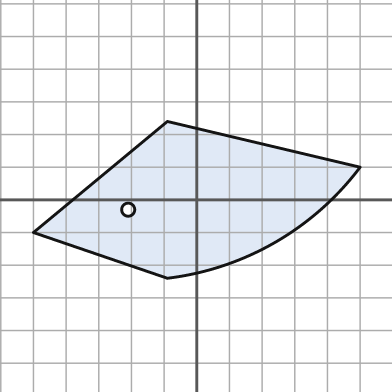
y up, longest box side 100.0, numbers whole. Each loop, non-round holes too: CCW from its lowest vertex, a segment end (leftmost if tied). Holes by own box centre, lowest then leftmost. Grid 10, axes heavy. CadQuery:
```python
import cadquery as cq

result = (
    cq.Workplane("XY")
    .moveTo(-9.0, -24.0)
    .threePointArc((24.0, -13.0), (50.0, 10.0))
    .lineTo(-9.0, 24.0)
    .lineTo(-50.0, -10.0)
    .close()
    .moveTo(-21.0, -3.0)
    .circle(2.0)
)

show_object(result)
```